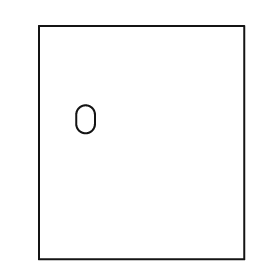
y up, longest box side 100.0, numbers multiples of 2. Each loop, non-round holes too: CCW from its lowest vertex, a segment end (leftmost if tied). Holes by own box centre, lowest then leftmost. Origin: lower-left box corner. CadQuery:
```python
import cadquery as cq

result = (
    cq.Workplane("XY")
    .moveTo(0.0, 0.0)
    .lineTo(88.0, 0.0)
    .lineTo(88.0, 100.0)
    .lineTo(0.0, 100.0)
    .close()
    .moveTo(16.0, 58.0)
    .threePointArc((20.0, 54.0), (24.0, 58.0))
    .lineTo(24.0, 62.0)
    .threePointArc((20.0, 66.0), (16.0, 62.0))
    .close()
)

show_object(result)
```